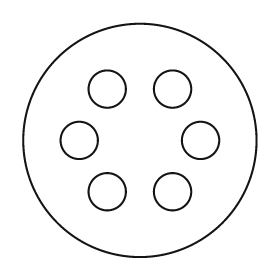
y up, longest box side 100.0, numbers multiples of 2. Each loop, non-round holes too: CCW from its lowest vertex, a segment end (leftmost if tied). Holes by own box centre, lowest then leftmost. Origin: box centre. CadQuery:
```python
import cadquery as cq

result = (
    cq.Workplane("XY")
    .moveTo(0.0, 0.0)
    .circle(50.0)
    .moveTo(-14.0, -22.0)
    .circle(8.0)
    .moveTo(14.0, -22.0)
    .circle(8.0)
    .moveTo(-26.0, 0.0)
    .circle(8.0)
    .moveTo(26.0, 0.0)
    .circle(8.0)
    .moveTo(-14.0, 22.0)
    .circle(8.0)
    .moveTo(14.0, 22.0)
    .circle(8.0)
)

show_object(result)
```